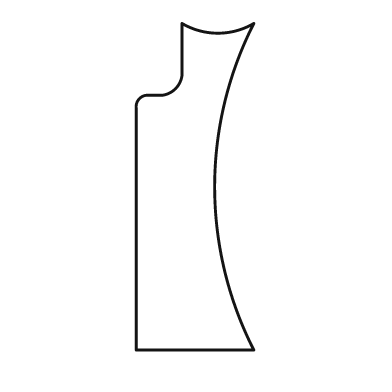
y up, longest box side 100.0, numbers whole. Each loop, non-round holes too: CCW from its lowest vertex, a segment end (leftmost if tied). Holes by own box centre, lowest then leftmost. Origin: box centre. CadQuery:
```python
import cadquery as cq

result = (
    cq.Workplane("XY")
    .moveTo(-18.0, -50.0)
    .lineTo(18.0, -50.0)
    .threePointArc((6.0, 0.0), (18.0, 50.0))
    .threePointArc((7.0, 47.0), (-4.0, 50.0))
    .lineTo(-4.0, 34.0)
    .threePointArc((-6.0, 30.0), (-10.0, 28.0))
    .lineTo(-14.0, 28.0)
    .threePointArc((-17.0, 27.0), (-18.0, 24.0))
    .close()
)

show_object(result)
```